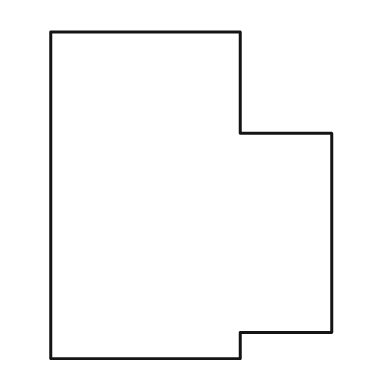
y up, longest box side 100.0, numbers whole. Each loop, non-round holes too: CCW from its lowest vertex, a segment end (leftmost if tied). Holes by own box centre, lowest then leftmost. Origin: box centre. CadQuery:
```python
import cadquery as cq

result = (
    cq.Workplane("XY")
    .moveTo(-43.0, -50.0)
    .lineTo(15.0, -50.0)
    .lineTo(15.0, -42.0)
    .lineTo(43.0, -42.0)
    .lineTo(43.0, 19.0)
    .lineTo(15.0, 19.0)
    .lineTo(15.0, 50.0)
    .lineTo(-43.0, 50.0)
    .close()
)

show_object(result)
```